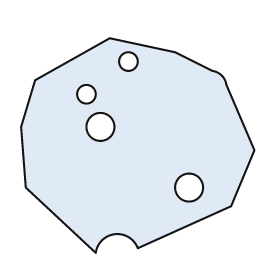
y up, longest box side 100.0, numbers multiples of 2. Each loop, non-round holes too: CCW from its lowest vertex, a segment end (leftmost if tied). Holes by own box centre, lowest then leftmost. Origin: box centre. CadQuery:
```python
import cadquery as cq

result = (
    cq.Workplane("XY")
    .moveTo(-18.0, -46.0)
    .threePointArc((-10.0, -38.0), (0.0, -44.0))
    .lineTo(40.0, -26.0)
    .lineTo(50.0, -2.0)
    .lineTo(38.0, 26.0)
    .threePointArc((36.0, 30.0), (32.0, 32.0))
    .lineTo(16.0, 40.0)
    .lineTo(-12.0, 46.0)
    .lineTo(-44.0, 28.0)
    .lineTo(-50.0, 8.0)
    .lineTo(-48.0, -18.0)
    .close()
    .moveTo(22.0, -18.0)
    .circle(6.0)
    .moveTo(-16.0, 8.0)
    .circle(6.0)
    .moveTo(-22.0, 22.0)
    .circle(4.0)
    .moveTo(-4.0, 36.0)
    .circle(4.0)
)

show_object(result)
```